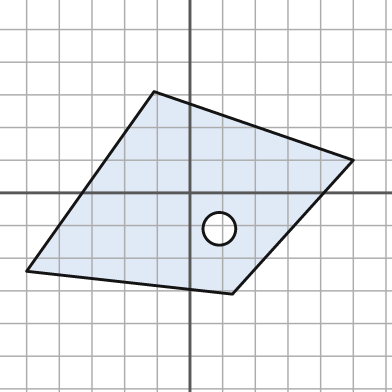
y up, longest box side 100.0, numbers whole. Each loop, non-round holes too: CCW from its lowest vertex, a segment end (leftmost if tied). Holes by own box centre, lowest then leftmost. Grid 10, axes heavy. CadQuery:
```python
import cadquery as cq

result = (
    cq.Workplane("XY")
    .moveTo(13.0, -31.0)
    .lineTo(50.0, 10.0)
    .lineTo(-11.0, 31.0)
    .lineTo(-50.0, -24.0)
    .close()
    .moveTo(9.0, -11.0)
    .circle(5.0)
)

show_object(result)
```